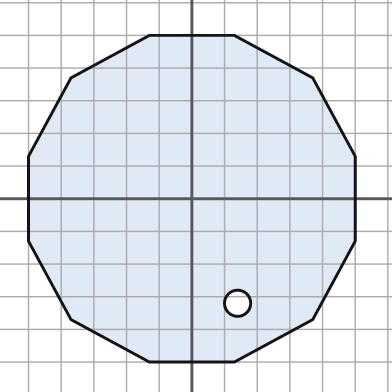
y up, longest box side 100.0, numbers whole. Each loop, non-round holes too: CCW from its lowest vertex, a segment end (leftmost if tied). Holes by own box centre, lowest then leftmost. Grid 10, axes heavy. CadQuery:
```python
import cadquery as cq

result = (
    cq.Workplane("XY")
    .moveTo(-13.0, -50.0)
    .lineTo(13.0, -50.0)
    .lineTo(37.0, -37.0)
    .lineTo(50.0, -13.0)
    .lineTo(50.0, 13.0)
    .lineTo(37.0, 37.0)
    .lineTo(13.0, 50.0)
    .lineTo(-13.0, 50.0)
    .lineTo(-37.0, 37.0)
    .lineTo(-50.0, 13.0)
    .lineTo(-50.0, -13.0)
    .lineTo(-37.0, -37.0)
    .close()
    .moveTo(14.0, -32.0)
    .circle(4.0)
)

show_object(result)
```